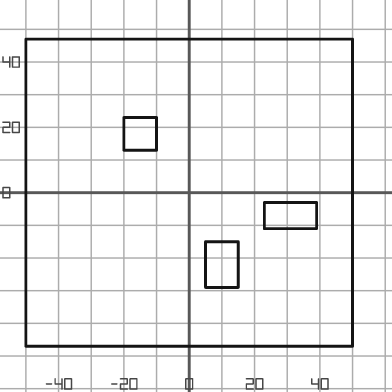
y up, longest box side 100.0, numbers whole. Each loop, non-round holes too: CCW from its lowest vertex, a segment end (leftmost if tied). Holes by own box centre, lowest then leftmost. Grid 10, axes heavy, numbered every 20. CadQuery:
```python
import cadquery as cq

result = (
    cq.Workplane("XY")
    .moveTo(-50.0, -47.0)
    .lineTo(50.0, -47.0)
    .lineTo(50.0, 47.0)
    .lineTo(-50.0, 47.0)
    .close()
    .moveTo(5.0, -29.0)
    .lineTo(15.0, -29.0)
    .lineTo(15.0, -15.0)
    .lineTo(5.0, -15.0)
    .close()
    .moveTo(23.0, -11.0)
    .lineTo(39.0, -11.0)
    .lineTo(39.0, -3.0)
    .lineTo(23.0, -3.0)
    .close()
    .moveTo(-20.0, 13.0)
    .lineTo(-10.0, 13.0)
    .lineTo(-10.0, 23.0)
    .lineTo(-20.0, 23.0)
    .close()
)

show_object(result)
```